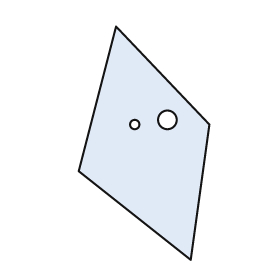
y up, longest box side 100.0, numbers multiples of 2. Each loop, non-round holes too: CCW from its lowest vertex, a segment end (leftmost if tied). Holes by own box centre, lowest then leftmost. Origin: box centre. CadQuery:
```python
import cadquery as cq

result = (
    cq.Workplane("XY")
    .moveTo(20.0, -50.0)
    .lineTo(28.0, 8.0)
    .lineTo(-12.0, 50.0)
    .lineTo(-28.0, -12.0)
    .close()
    .moveTo(-4.0, 8.0)
    .circle(2.0)
    .moveTo(10.0, 10.0)
    .circle(4.0)
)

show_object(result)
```